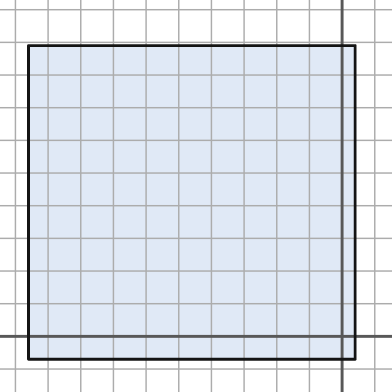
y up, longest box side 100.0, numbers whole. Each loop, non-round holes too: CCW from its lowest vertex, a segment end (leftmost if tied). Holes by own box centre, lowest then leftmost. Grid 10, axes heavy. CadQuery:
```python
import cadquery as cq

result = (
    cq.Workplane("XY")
    .moveTo(-96.0, -7.0)
    .lineTo(4.0, -7.0)
    .lineTo(4.0, 89.0)
    .lineTo(-96.0, 89.0)
    .close()
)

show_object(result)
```